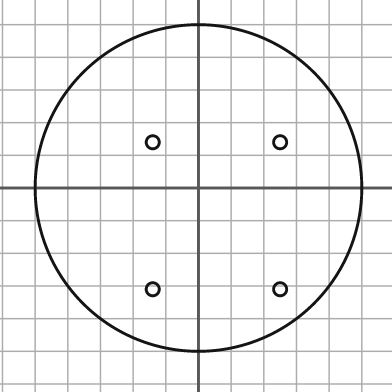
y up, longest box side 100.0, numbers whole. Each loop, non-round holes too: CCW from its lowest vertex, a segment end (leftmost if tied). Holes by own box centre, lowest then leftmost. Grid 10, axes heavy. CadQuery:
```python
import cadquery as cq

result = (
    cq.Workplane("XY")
    .moveTo(0.0, 0.0)
    .circle(50.0)
    .moveTo(-14.0, -31.0)
    .circle(2.0)
    .moveTo(25.0, -31.0)
    .circle(2.0)
    .moveTo(-14.0, 14.0)
    .circle(2.0)
    .moveTo(25.0, 14.0)
    .circle(2.0)
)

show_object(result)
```